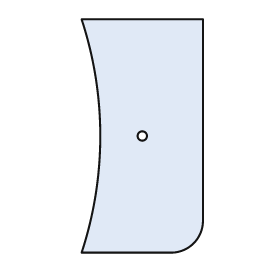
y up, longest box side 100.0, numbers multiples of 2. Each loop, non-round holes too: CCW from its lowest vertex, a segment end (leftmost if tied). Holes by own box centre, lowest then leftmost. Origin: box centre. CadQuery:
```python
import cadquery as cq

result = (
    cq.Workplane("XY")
    .moveTo(-26.0, -50.0)
    .lineTo(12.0, -50.0)
    .threePointArc((22.0, -46.0), (26.0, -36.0))
    .lineTo(26.0, 50.0)
    .lineTo(-26.0, 50.0)
    .threePointArc((-18.0, 0.0), (-26.0, -50.0))
    .close()
    .moveTo(0.0, 0.0)
    .circle(2.0)
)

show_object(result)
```